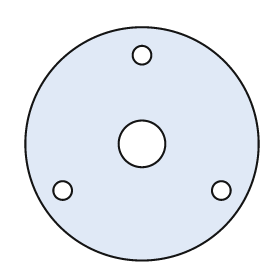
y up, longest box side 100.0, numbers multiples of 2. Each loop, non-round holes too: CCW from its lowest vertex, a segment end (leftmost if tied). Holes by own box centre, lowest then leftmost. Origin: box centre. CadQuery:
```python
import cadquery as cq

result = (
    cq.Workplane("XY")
    .moveTo(0.0, 0.0)
    .circle(50.0)
    .moveTo(-34.0, -20.0)
    .circle(4.0)
    .moveTo(34.0, -20.0)
    .circle(4.0)
    .moveTo(0.0, 0.0)
    .circle(10.0)
    .moveTo(0.0, 38.0)
    .circle(4.0)
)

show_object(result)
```